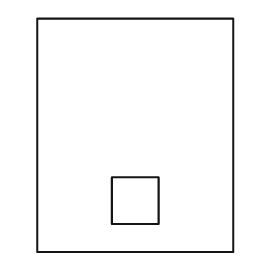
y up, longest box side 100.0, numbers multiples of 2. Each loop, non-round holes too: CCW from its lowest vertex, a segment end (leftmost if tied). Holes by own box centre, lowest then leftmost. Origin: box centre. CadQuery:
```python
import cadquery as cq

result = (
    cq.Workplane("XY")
    .moveTo(-42.0, -50.0)
    .lineTo(42.0, -50.0)
    .lineTo(42.0, 50.0)
    .lineTo(-42.0, 50.0)
    .close()
    .moveTo(-10.0, -38.0)
    .lineTo(10.0, -38.0)
    .lineTo(10.0, -18.0)
    .lineTo(-10.0, -18.0)
    .close()
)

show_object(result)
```